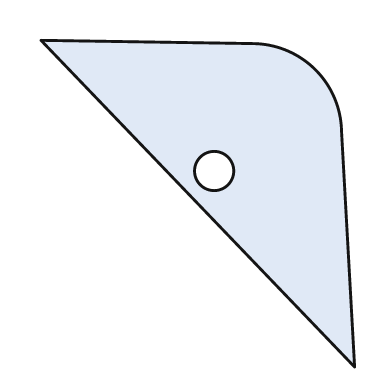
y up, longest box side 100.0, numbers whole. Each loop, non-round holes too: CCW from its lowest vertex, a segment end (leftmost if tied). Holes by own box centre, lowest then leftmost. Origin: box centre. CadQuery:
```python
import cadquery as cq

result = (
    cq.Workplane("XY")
    .moveTo(48.0, -50.0)
    .lineTo(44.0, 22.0)
    .threePointArc((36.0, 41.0), (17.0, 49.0))
    .lineTo(-48.0, 50.0)
    .close()
    .moveTo(5.0, 10.0)
    .circle(6.0)
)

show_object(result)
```